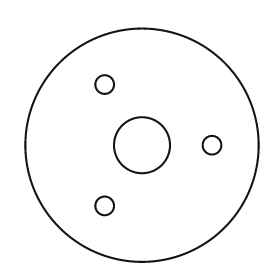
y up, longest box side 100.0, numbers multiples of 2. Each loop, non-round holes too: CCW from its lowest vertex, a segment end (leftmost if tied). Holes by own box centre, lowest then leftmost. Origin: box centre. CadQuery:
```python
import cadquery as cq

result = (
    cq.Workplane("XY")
    .moveTo(0.0, 0.0)
    .circle(50.0)
    .moveTo(-16.0, -26.0)
    .circle(4.0)
    .moveTo(0.0, 0.0)
    .circle(12.0)
    .moveTo(30.0, 0.0)
    .circle(4.0)
    .moveTo(-16.0, 26.0)
    .circle(4.0)
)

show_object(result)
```